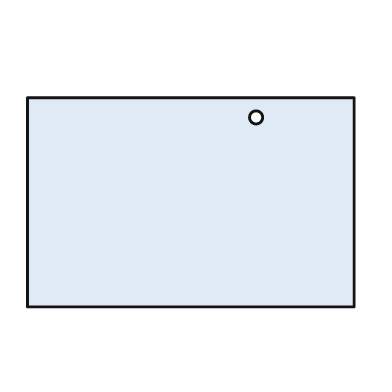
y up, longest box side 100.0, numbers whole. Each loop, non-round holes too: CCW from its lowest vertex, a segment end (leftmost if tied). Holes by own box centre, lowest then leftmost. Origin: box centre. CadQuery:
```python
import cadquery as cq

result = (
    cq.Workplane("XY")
    .moveTo(-50.0, -32.0)
    .lineTo(50.0, -32.0)
    .lineTo(50.0, 32.0)
    .lineTo(-50.0, 32.0)
    .close()
    .moveTo(20.0, 26.0)
    .circle(2.0)
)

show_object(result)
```